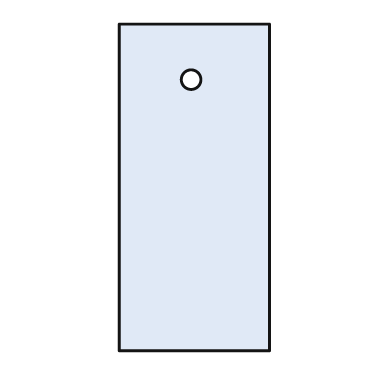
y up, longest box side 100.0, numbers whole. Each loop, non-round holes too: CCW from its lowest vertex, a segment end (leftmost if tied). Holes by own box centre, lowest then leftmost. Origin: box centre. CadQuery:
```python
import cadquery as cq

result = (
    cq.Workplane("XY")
    .moveTo(-23.0, -50.0)
    .lineTo(23.0, -50.0)
    .lineTo(23.0, 50.0)
    .lineTo(-23.0, 50.0)
    .close()
    .moveTo(-1.0, 33.0)
    .circle(3.0)
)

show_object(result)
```